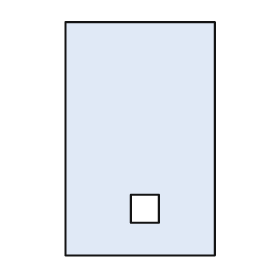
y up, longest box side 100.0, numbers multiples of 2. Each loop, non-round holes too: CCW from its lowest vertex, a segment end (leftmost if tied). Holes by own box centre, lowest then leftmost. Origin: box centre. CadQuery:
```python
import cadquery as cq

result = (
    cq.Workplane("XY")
    .moveTo(-32.0, -50.0)
    .lineTo(32.0, -50.0)
    .lineTo(32.0, 50.0)
    .lineTo(-32.0, 50.0)
    .close()
    .moveTo(-4.0, -36.0)
    .lineTo(8.0, -36.0)
    .lineTo(8.0, -24.0)
    .lineTo(-4.0, -24.0)
    .close()
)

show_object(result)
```